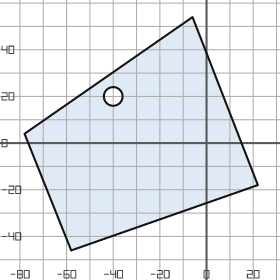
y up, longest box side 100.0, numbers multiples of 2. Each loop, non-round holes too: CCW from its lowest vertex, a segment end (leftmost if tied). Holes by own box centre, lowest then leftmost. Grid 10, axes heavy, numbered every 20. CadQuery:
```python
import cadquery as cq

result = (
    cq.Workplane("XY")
    .moveTo(-58.0, -46.0)
    .lineTo(22.0, -18.0)
    .lineTo(-6.0, 54.0)
    .lineTo(-78.0, 4.0)
    .close()
    .moveTo(-40.0, 20.0)
    .circle(4.0)
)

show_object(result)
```